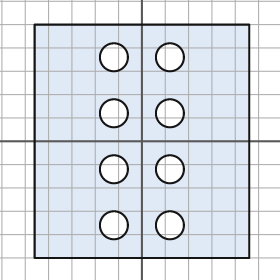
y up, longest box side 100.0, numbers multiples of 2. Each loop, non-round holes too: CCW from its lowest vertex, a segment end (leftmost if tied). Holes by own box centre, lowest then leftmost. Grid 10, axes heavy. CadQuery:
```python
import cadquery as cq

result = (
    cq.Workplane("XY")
    .moveTo(-46.0, -50.0)
    .lineTo(46.0, -50.0)
    .lineTo(46.0, 50.0)
    .lineTo(-46.0, 50.0)
    .close()
    .moveTo(-12.0, -36.0)
    .circle(6.0)
    .moveTo(12.0, -36.0)
    .circle(6.0)
    .moveTo(-12.0, -12.0)
    .circle(6.0)
    .moveTo(12.0, -12.0)
    .circle(6.0)
    .moveTo(-12.0, 12.0)
    .circle(6.0)
    .moveTo(12.0, 12.0)
    .circle(6.0)
    .moveTo(-12.0, 36.0)
    .circle(6.0)
    .moveTo(12.0, 36.0)
    .circle(6.0)
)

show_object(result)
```